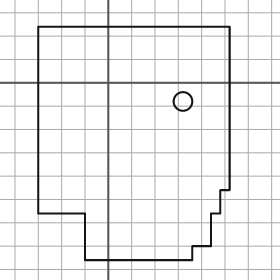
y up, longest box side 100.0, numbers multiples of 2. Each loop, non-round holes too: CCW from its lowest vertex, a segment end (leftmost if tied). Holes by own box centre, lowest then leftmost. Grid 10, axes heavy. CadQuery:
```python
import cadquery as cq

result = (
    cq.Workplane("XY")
    .moveTo(-10.0, -76.0)
    .lineTo(36.0, -76.0)
    .lineTo(36.0, -70.0)
    .lineTo(44.0, -70.0)
    .lineTo(44.0, -56.0)
    .lineTo(48.0, -56.0)
    .lineTo(48.0, -46.0)
    .lineTo(52.0, -46.0)
    .lineTo(52.0, 24.0)
    .lineTo(-30.0, 24.0)
    .lineTo(-30.0, -56.0)
    .lineTo(-10.0, -56.0)
    .close()
    .moveTo(32.0, -8.0)
    .circle(4.0)
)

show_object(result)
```